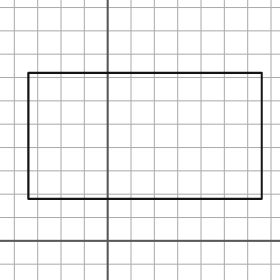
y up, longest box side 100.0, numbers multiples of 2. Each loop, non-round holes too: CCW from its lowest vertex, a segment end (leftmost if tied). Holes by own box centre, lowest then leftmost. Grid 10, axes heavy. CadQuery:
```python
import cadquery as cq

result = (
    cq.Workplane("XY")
    .moveTo(-34.0, 18.0)
    .lineTo(66.0, 18.0)
    .lineTo(66.0, 72.0)
    .lineTo(-34.0, 72.0)
    .close()
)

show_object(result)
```